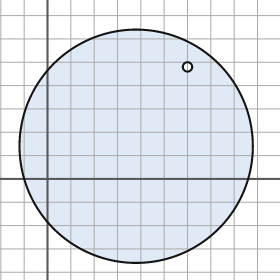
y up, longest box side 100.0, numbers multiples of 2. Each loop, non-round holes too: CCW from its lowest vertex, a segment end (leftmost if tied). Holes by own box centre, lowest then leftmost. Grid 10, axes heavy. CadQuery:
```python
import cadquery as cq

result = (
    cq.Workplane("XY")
    .moveTo(38.0, 14.0)
    .circle(50.0)
    .moveTo(60.0, 48.0)
    .circle(2.0)
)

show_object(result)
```